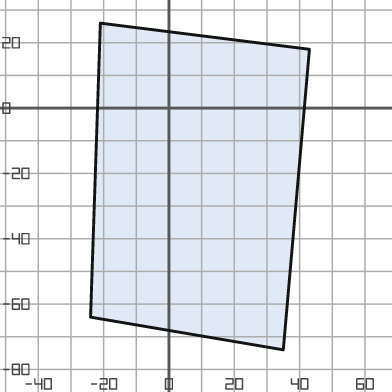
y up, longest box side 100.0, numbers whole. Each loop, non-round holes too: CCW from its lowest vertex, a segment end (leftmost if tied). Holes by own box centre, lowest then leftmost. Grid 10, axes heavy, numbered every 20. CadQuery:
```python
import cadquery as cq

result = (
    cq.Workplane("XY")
    .moveTo(35.0, -74.0)
    .lineTo(43.0, 18.0)
    .lineTo(-21.0, 26.0)
    .lineTo(-24.0, -64.0)
    .close()
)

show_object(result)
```